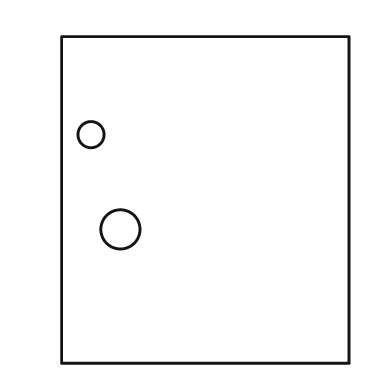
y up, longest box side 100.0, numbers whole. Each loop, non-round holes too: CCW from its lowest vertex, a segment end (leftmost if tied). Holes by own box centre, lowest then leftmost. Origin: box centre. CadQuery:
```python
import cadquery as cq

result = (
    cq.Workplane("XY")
    .moveTo(-44.0, -50.0)
    .lineTo(44.0, -50.0)
    .lineTo(44.0, 50.0)
    .lineTo(-44.0, 50.0)
    .close()
    .moveTo(-26.0, -9.0)
    .circle(6.0)
    .moveTo(-35.0, 20.0)
    .circle(4.0)
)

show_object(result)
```